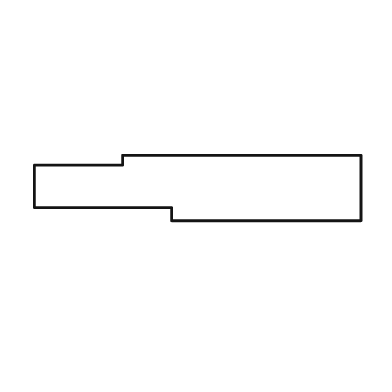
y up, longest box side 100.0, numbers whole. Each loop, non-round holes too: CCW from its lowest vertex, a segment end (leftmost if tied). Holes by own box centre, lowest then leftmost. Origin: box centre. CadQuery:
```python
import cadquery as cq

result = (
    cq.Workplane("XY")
    .moveTo(-8.0, -10.0)
    .lineTo(50.0, -10.0)
    .lineTo(50.0, 10.0)
    .lineTo(-23.0, 10.0)
    .lineTo(-23.0, 7.0)
    .lineTo(-50.0, 7.0)
    .lineTo(-50.0, -6.0)
    .lineTo(-8.0, -6.0)
    .close()
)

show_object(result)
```